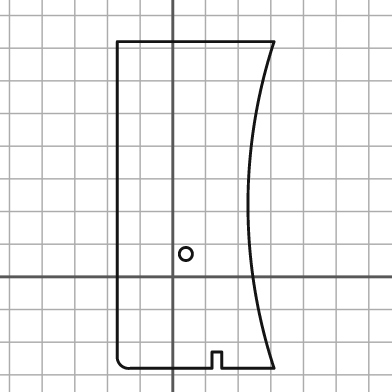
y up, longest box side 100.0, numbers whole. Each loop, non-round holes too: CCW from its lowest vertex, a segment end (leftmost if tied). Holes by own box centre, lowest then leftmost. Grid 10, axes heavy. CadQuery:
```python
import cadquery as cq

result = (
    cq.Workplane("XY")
    .moveTo(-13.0, -28.0)
    .lineTo(12.0, -28.0)
    .lineTo(12.0, -23.0)
    .lineTo(15.0, -23.0)
    .lineTo(15.0, -28.0)
    .lineTo(31.0, -28.0)
    .threePointArc((23.0, 22.0), (31.0, 72.0))
    .lineTo(-17.0, 72.0)
    .lineTo(-17.0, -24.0)
    .threePointArc((-16.0, -27.0), (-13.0, -28.0))
    .close()
    .moveTo(4.0, 7.0)
    .circle(2.0)
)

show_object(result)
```